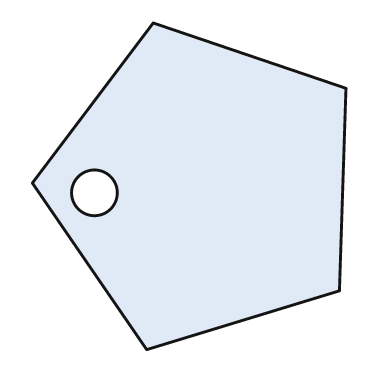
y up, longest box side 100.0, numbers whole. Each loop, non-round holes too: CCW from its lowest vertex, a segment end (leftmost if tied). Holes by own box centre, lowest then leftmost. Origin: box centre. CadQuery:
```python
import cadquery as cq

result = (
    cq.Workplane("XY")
    .moveTo(-13.0, -50.0)
    .lineTo(46.0, -32.0)
    .lineTo(48.0, 30.0)
    .lineTo(-11.0, 50.0)
    .lineTo(-48.0, 1.0)
    .close()
    .moveTo(-29.0, -2.0)
    .circle(7.0)
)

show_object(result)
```